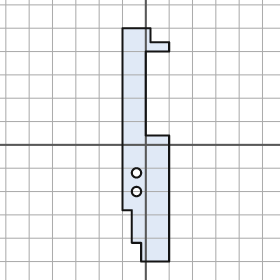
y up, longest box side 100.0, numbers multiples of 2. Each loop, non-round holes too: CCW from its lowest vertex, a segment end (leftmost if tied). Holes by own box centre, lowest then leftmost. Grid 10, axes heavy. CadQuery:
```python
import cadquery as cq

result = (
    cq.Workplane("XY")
    .moveTo(-2.0, -50.0)
    .lineTo(10.0, -50.0)
    .lineTo(10.0, 4.0)
    .lineTo(0.0, 4.0)
    .lineTo(0.0, 40.0)
    .lineTo(10.0, 40.0)
    .lineTo(10.0, 44.0)
    .lineTo(2.0, 44.0)
    .lineTo(2.0, 50.0)
    .lineTo(-10.0, 50.0)
    .lineTo(-10.0, -28.0)
    .lineTo(-6.0, -28.0)
    .lineTo(-6.0, -42.0)
    .lineTo(-2.0, -42.0)
    .close()
    .moveTo(-4.0, -20.0)
    .circle(2.0)
    .moveTo(-4.0, -12.0)
    .circle(2.0)
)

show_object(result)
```